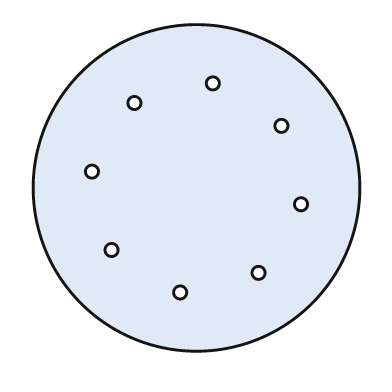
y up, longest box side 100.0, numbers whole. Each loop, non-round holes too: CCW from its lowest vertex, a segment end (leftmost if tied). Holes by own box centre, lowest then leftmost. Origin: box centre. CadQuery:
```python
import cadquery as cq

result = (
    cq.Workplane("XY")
    .moveTo(0.0, 0.0)
    .circle(50.0)
    .moveTo(-5.0, -32.0)
    .circle(2.0)
    .moveTo(19.0, -26.0)
    .circle(2.0)
    .moveTo(-26.0, -19.0)
    .circle(2.0)
    .moveTo(32.0, -5.0)
    .circle(2.0)
    .moveTo(-32.0, 5.0)
    .circle(2.0)
    .moveTo(26.0, 19.0)
    .circle(2.0)
    .moveTo(-19.0, 26.0)
    .circle(2.0)
    .moveTo(5.0, 32.0)
    .circle(2.0)
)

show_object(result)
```